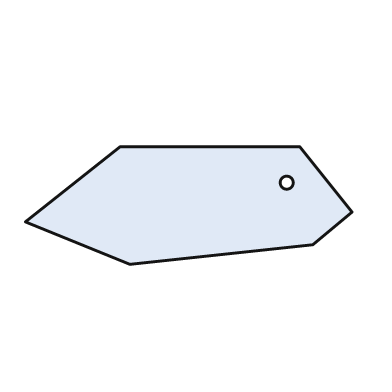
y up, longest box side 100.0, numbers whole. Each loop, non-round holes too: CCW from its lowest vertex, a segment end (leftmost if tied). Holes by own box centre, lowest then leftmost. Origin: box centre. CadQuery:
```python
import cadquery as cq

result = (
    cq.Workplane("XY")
    .moveTo(-18.0, -18.0)
    .lineTo(38.0, -12.0)
    .lineTo(50.0, -2.0)
    .lineTo(34.0, 18.0)
    .lineTo(-21.0, 18.0)
    .lineTo(-50.0, -5.0)
    .close()
    .moveTo(30.0, 7.0)
    .circle(2.0)
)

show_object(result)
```